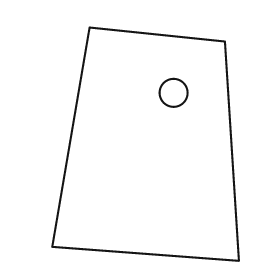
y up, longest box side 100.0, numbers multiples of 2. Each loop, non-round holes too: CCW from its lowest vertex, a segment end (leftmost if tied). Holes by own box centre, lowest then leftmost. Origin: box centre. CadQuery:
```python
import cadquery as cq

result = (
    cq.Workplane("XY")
    .moveTo(40.0, -50.0)
    .lineTo(34.0, 44.0)
    .lineTo(-24.0, 50.0)
    .lineTo(-40.0, -44.0)
    .close()
    .moveTo(12.0, 22.0)
    .circle(6.0)
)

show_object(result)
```